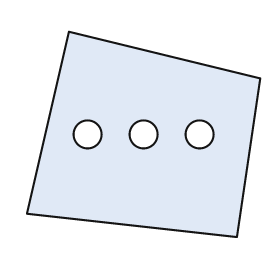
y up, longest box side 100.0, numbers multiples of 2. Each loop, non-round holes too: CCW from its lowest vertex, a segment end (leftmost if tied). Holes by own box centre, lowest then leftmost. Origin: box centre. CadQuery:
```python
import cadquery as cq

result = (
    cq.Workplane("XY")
    .moveTo(40.0, -44.0)
    .lineTo(50.0, 24.0)
    .lineTo(-32.0, 44.0)
    .lineTo(-50.0, -34.0)
    .close()
    .moveTo(-24.0, 0.0)
    .circle(6.0)
    .moveTo(0.0, 0.0)
    .circle(6.0)
    .moveTo(24.0, 0.0)
    .circle(6.0)
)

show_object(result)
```